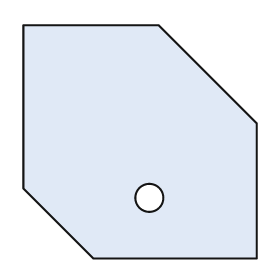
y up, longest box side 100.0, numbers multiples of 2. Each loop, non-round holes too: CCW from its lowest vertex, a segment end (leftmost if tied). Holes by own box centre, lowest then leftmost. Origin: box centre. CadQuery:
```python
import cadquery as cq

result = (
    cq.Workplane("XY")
    .moveTo(-20.0, -50.0)
    .lineTo(50.0, -50.0)
    .lineTo(50.0, 8.0)
    .lineTo(8.0, 50.0)
    .lineTo(-50.0, 50.0)
    .lineTo(-50.0, -20.0)
    .close()
    .moveTo(4.0, -24.0)
    .circle(6.0)
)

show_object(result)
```